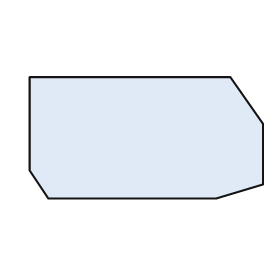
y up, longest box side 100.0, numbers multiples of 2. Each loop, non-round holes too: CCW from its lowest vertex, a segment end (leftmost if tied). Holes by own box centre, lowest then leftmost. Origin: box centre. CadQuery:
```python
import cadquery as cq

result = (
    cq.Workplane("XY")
    .moveTo(-42.0, -26.0)
    .lineTo(30.0, -26.0)
    .lineTo(50.0, -20.0)
    .lineTo(50.0, 6.0)
    .lineTo(36.0, 26.0)
    .lineTo(-50.0, 26.0)
    .lineTo(-50.0, -14.0)
    .close()
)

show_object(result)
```